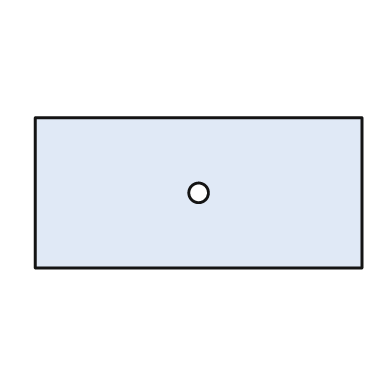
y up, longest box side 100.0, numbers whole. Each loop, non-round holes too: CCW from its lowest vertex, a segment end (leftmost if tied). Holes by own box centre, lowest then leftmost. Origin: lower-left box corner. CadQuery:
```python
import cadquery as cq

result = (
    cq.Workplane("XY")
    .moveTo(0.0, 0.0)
    .lineTo(100.0, 0.0)
    .lineTo(100.0, 46.0)
    .lineTo(0.0, 46.0)
    .close()
    .moveTo(50.0, 23.0)
    .circle(3.0)
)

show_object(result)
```